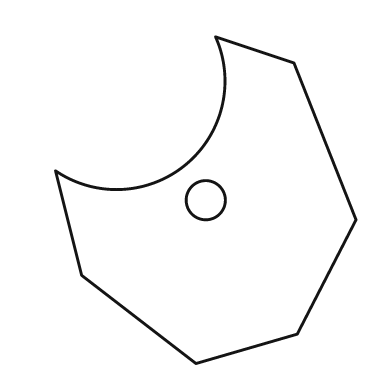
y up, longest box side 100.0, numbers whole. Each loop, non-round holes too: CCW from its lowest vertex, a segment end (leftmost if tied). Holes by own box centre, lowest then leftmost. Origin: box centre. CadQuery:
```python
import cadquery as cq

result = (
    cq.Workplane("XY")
    .moveTo(-3.0, -50.0)
    .lineTo(28.0, -41.0)
    .lineTo(46.0, -6.0)
    .lineTo(27.0, 42.0)
    .lineTo(3.0, 50.0)
    .threePointArc((-6.0, 11.0), (-46.0, 9.0))
    .lineTo(-38.0, -23.0)
    .close()
    .moveTo(0.0, 0.0)
    .circle(6.0)
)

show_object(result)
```